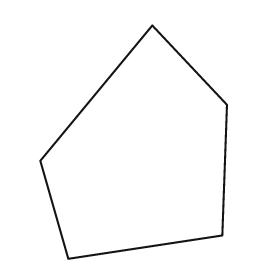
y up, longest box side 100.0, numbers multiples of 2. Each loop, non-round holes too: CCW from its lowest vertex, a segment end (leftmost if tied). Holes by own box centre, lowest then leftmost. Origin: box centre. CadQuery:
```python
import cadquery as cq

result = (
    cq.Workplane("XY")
    .moveTo(-28.0, -50.0)
    .lineTo(38.0, -40.0)
    .lineTo(40.0, 16.0)
    .lineTo(8.0, 50.0)
    .lineTo(-40.0, -8.0)
    .close()
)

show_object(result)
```